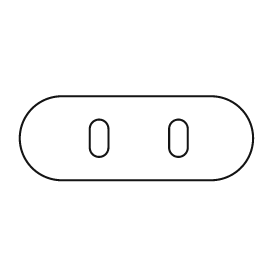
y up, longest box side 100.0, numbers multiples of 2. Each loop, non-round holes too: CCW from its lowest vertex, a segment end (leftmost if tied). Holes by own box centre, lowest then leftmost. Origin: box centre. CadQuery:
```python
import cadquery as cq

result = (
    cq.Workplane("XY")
    .moveTo(-32.0, -18.0)
    .lineTo(32.0, -18.0)
    .threePointArc((50.0, 0.0), (32.0, 18.0))
    .lineTo(-32.0, 18.0)
    .threePointArc((-50.0, 0.0), (-32.0, -18.0))
    .close()
    .moveTo(-20.0, -4.0)
    .threePointArc((-16.0, -8.0), (-12.0, -4.0))
    .lineTo(-12.0, 4.0)
    .threePointArc((-16.0, 8.0), (-20.0, 4.0))
    .close()
    .moveTo(14.0, -4.0)
    .threePointArc((18.0, -8.0), (22.0, -4.0))
    .lineTo(22.0, 4.0)
    .threePointArc((18.0, 8.0), (14.0, 4.0))
    .close()
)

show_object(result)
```